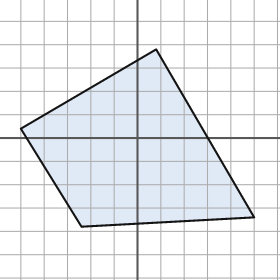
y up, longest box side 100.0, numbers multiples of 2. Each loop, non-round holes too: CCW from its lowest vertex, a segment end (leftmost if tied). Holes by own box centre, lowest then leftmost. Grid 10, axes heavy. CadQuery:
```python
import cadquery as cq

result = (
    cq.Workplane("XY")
    .moveTo(-24.0, -38.0)
    .lineTo(50.0, -34.0)
    .lineTo(8.0, 38.0)
    .lineTo(-50.0, 4.0)
    .close()
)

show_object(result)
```